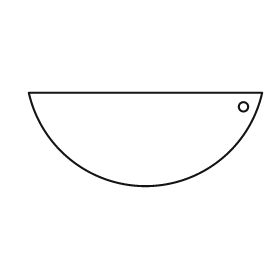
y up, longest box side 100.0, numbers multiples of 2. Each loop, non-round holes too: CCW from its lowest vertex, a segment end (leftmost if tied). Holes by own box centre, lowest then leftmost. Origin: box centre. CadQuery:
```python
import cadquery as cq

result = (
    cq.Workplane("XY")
    .moveTo(-50.0, 20.0)
    .threePointArc((0.0, -20.0), (50.0, 20.0))
    .close()
    .moveTo(42.0, 14.0)
    .circle(2.0)
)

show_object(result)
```